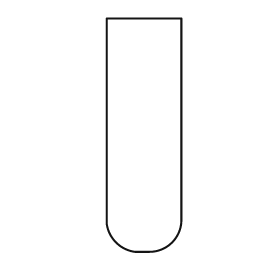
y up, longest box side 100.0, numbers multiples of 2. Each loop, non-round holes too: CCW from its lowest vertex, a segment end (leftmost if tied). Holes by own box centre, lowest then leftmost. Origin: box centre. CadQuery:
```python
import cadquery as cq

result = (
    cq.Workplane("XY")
    .moveTo(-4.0, -50.0)
    .lineTo(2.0, -50.0)
    .threePointArc((12.0, -46.0), (16.0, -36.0))
    .lineTo(16.0, 50.0)
    .lineTo(-16.0, 50.0)
    .lineTo(-16.0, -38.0)
    .threePointArc((-12.0, -46.0), (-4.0, -50.0))
    .close()
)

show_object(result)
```